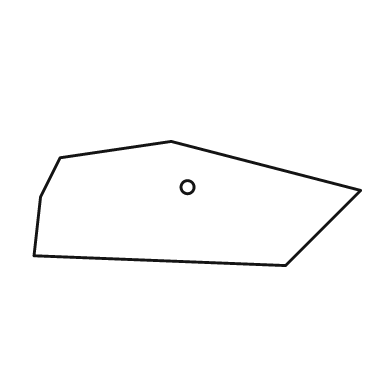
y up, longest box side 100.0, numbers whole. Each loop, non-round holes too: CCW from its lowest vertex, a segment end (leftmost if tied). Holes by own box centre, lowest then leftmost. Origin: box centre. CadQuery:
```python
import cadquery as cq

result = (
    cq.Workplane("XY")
    .moveTo(27.0, -19.0)
    .lineTo(50.0, 4.0)
    .lineTo(-8.0, 19.0)
    .lineTo(-42.0, 14.0)
    .lineTo(-48.0, 2.0)
    .lineTo(-50.0, -16.0)
    .close()
    .moveTo(-3.0, 5.0)
    .circle(2.0)
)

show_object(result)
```